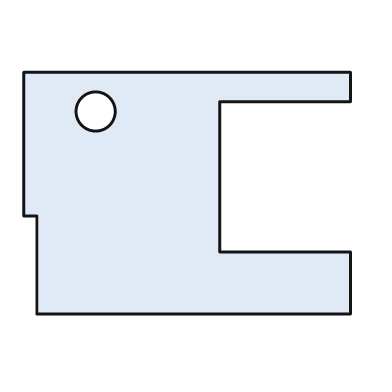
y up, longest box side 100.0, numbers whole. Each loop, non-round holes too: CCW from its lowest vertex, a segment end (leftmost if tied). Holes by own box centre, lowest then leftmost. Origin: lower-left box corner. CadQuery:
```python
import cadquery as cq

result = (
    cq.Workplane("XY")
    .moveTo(4.0, 0.0)
    .lineTo(100.0, 0.0)
    .lineTo(100.0, 19.0)
    .lineTo(60.0, 19.0)
    .lineTo(60.0, 65.0)
    .lineTo(100.0, 65.0)
    .lineTo(100.0, 74.0)
    .lineTo(0.0, 74.0)
    .lineTo(0.0, 30.0)
    .lineTo(4.0, 30.0)
    .close()
    .moveTo(22.0, 62.0)
    .circle(6.0)
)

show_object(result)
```